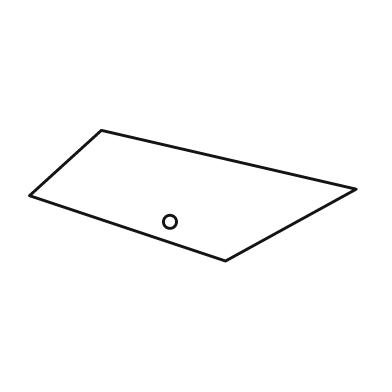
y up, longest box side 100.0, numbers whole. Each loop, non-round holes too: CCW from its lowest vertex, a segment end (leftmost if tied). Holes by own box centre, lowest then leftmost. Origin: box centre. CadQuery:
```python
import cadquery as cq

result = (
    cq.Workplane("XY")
    .moveTo(10.0, -20.0)
    .lineTo(50.0, 2.0)
    .lineTo(-28.0, 20.0)
    .lineTo(-50.0, 0.0)
    .close()
    .moveTo(-7.0, -8.0)
    .circle(2.0)
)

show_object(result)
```